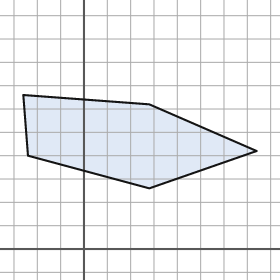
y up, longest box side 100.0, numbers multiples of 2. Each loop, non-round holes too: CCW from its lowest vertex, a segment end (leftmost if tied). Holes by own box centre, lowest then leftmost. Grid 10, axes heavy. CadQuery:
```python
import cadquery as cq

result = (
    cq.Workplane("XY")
    .moveTo(28.0, 26.0)
    .lineTo(74.0, 42.0)
    .lineTo(28.0, 62.0)
    .lineTo(-26.0, 66.0)
    .lineTo(-24.0, 40.0)
    .close()
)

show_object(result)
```